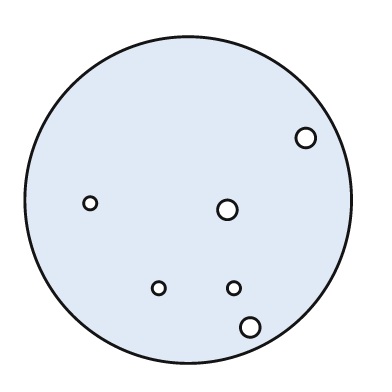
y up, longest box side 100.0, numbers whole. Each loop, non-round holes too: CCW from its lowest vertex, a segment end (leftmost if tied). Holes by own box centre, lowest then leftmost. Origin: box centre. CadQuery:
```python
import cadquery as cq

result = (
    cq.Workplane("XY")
    .moveTo(0.0, 0.0)
    .circle(50.0)
    .moveTo(19.0, -39.0)
    .circle(3.0)
    .moveTo(-9.0, -27.0)
    .circle(2.0)
    .moveTo(14.0, -27.0)
    .circle(2.0)
    .moveTo(12.0, -3.0)
    .circle(3.0)
    .moveTo(-30.0, -1.0)
    .circle(2.0)
    .moveTo(36.0, 19.0)
    .circle(3.0)
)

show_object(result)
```